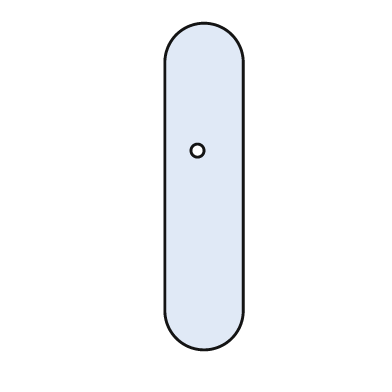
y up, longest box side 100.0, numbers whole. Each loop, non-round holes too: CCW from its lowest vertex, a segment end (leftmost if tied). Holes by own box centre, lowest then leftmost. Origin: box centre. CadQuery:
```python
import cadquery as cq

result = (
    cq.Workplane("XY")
    .moveTo(-12.0, -38.0)
    .threePointArc((0.0, -50.0), (12.0, -38.0))
    .lineTo(12.0, 38.0)
    .threePointArc((0.0, 50.0), (-12.0, 38.0))
    .close()
    .moveTo(-2.0, 11.0)
    .circle(2.0)
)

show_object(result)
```